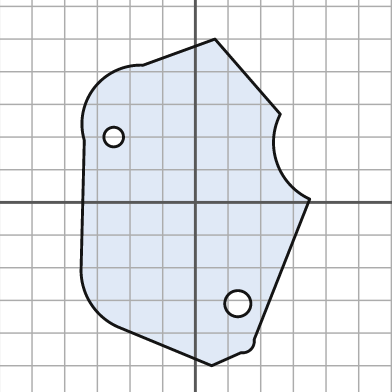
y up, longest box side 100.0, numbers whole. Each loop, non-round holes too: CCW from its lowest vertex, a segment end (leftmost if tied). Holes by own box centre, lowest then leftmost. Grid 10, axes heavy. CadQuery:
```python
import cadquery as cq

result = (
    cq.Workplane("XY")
    .moveTo(5.0, -50.0)
    .lineTo(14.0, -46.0)
    .threePointArc((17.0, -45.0), (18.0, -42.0))
    .lineTo(35.0, 1.0)
    .threePointArc((25.0, 12.0), (26.0, 27.0))
    .lineTo(6.0, 50.0)
    .lineTo(-16.0, 42.0)
    .threePointArc((-31.0, 35.0), (-34.0, 19.0))
    .lineTo(-35.0, -21.0)
    .threePointArc((-32.0, -31.0), (-24.0, -38.0))
    .close()
    .moveTo(13.0, -31.0)
    .circle(4.0)
    .moveTo(-25.0, 20.0)
    .circle(3.0)
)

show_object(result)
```